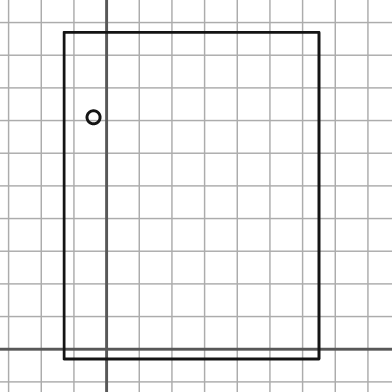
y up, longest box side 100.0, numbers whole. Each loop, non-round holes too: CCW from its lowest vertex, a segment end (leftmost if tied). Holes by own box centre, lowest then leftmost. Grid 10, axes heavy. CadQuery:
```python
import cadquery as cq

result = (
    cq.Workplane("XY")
    .moveTo(-13.0, -3.0)
    .lineTo(65.0, -3.0)
    .lineTo(65.0, 97.0)
    .lineTo(-13.0, 97.0)
    .close()
    .moveTo(-4.0, 71.0)
    .circle(2.0)
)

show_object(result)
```